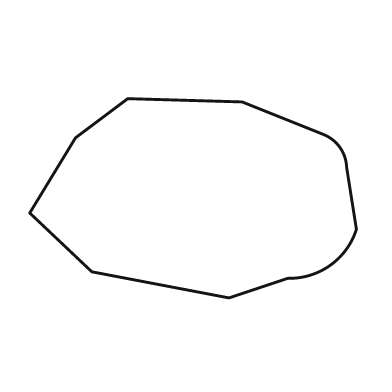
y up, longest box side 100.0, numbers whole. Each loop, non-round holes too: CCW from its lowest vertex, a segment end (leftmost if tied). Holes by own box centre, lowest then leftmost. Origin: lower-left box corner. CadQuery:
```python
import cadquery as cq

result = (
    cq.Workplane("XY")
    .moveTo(61.0, 0.0)
    .lineTo(79.0, 6.0)
    .threePointArc((92.0, 10.0), (100.0, 21.0))
    .lineTo(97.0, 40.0)
    .threePointArc((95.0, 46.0), (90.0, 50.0))
    .lineTo(65.0, 60.0)
    .lineTo(30.0, 61.0)
    .lineTo(14.0, 49.0)
    .lineTo(0.0, 26.0)
    .lineTo(19.0, 8.0)
    .close()
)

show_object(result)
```